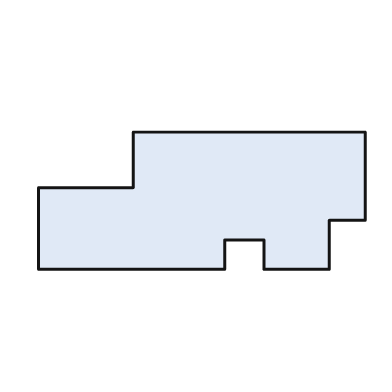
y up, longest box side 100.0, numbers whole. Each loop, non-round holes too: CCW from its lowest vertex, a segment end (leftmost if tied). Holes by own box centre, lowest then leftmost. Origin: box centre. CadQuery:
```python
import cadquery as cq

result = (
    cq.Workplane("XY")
    .moveTo(-50.0, -21.0)
    .lineTo(7.0, -21.0)
    .lineTo(7.0, -12.0)
    .lineTo(19.0, -12.0)
    .lineTo(19.0, -21.0)
    .lineTo(39.0, -21.0)
    .lineTo(39.0, -6.0)
    .lineTo(50.0, -6.0)
    .lineTo(50.0, 21.0)
    .lineTo(-21.0, 21.0)
    .lineTo(-21.0, 4.0)
    .lineTo(-50.0, 4.0)
    .close()
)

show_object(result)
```